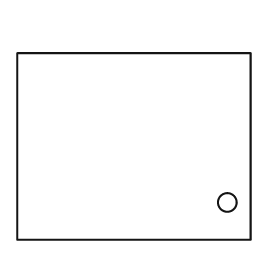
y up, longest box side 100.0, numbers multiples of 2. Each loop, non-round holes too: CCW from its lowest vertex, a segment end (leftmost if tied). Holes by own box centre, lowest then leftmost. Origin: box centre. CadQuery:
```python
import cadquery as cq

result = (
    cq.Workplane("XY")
    .moveTo(-50.0, -40.0)
    .lineTo(50.0, -40.0)
    .lineTo(50.0, 40.0)
    .lineTo(-50.0, 40.0)
    .close()
    .moveTo(40.0, -24.0)
    .circle(4.0)
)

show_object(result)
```